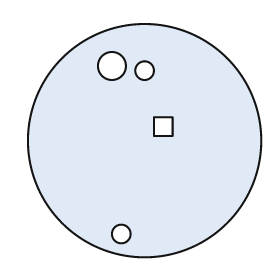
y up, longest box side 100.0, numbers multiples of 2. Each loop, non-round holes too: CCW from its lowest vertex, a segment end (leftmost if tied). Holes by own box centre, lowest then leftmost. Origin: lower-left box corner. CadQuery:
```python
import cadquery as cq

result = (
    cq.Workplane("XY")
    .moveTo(50.0, 50.0)
    .circle(50.0)
    .moveTo(40.0, 10.0)
    .circle(4.0)
    .moveTo(54.0, 52.0)
    .lineTo(62.0, 52.0)
    .lineTo(62.0, 60.0)
    .lineTo(54.0, 60.0)
    .close()
    .moveTo(50.0, 80.0)
    .circle(4.0)
    .moveTo(36.0, 82.0)
    .circle(6.0)
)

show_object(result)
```